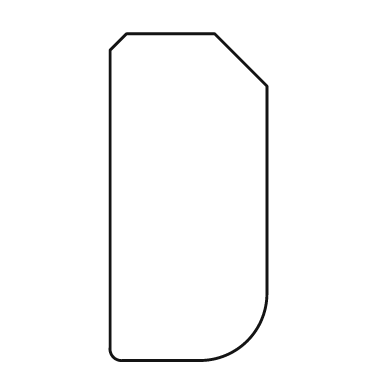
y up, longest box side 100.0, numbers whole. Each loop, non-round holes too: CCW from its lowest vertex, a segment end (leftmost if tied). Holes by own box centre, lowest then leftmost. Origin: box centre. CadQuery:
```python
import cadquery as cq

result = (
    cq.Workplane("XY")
    .moveTo(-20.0, -50.0)
    .lineTo(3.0, -50.0)
    .threePointArc((18.0, -44.0), (24.0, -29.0))
    .lineTo(24.0, 34.0)
    .lineTo(8.0, 50.0)
    .lineTo(-19.0, 50.0)
    .lineTo(-24.0, 45.0)
    .lineTo(-24.0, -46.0)
    .threePointArc((-23.0, -49.0), (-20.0, -50.0))
    .close()
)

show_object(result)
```